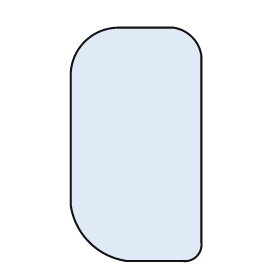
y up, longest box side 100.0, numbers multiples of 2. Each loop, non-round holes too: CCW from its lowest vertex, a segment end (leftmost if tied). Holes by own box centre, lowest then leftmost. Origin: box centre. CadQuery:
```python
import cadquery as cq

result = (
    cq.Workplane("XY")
    .moveTo(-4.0, -50.0)
    .lineTo(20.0, -50.0)
    .threePointArc((26.0, -48.0), (28.0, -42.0))
    .lineTo(28.0, 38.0)
    .threePointArc((24.0, 46.0), (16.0, 50.0))
    .lineTo(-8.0, 50.0)
    .threePointArc((-22.0, 44.0), (-28.0, 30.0))
    .lineTo(-28.0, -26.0)
    .threePointArc((-20.0, -42.0), (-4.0, -50.0))
    .close()
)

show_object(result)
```